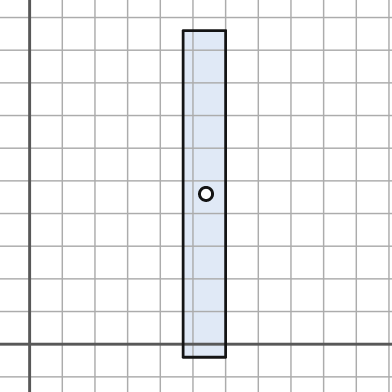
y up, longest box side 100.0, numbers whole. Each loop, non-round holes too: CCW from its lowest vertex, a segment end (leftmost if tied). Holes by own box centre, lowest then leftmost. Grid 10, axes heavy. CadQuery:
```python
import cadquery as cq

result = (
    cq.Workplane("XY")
    .moveTo(47.0, -4.0)
    .lineTo(60.0, -4.0)
    .lineTo(60.0, 96.0)
    .lineTo(47.0, 96.0)
    .close()
    .moveTo(54.0, 46.0)
    .circle(2.0)
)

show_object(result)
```